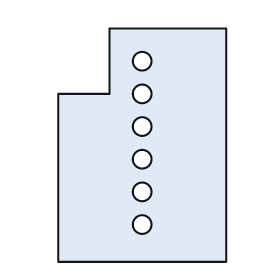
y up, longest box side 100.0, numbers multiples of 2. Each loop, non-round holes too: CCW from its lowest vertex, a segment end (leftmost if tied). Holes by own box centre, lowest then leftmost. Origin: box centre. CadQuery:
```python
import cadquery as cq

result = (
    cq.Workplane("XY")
    .moveTo(-36.0, -50.0)
    .lineTo(36.0, -50.0)
    .lineTo(36.0, 50.0)
    .lineTo(-14.0, 50.0)
    .lineTo(-14.0, 22.0)
    .lineTo(-36.0, 22.0)
    .close()
    .moveTo(0.0, -34.0)
    .circle(4.0)
    .moveTo(0.0, -20.0)
    .circle(4.0)
    .moveTo(0.0, -6.0)
    .circle(4.0)
    .moveTo(0.0, 8.0)
    .circle(4.0)
    .moveTo(0.0, 22.0)
    .circle(4.0)
    .moveTo(0.0, 36.0)
    .circle(4.0)
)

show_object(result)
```